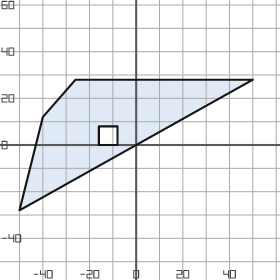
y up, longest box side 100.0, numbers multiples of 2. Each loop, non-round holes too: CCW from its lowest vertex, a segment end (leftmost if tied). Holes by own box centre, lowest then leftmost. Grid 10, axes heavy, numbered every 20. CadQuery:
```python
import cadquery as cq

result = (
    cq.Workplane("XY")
    .moveTo(-50.0, -28.0)
    .lineTo(50.0, 28.0)
    .lineTo(-26.0, 28.0)
    .lineTo(-40.0, 12.0)
    .close()
    .moveTo(-16.0, 0.0)
    .lineTo(-8.0, 0.0)
    .lineTo(-8.0, 8.0)
    .lineTo(-16.0, 8.0)
    .close()
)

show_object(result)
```